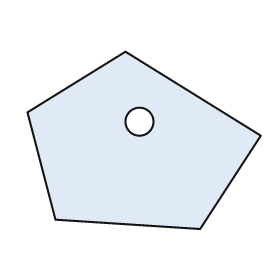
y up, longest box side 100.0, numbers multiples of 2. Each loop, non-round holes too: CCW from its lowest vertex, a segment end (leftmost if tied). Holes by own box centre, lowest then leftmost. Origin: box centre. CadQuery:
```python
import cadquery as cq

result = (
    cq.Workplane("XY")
    .moveTo(24.0, -38.0)
    .lineTo(50.0, 2.0)
    .lineTo(-8.0, 38.0)
    .lineTo(-50.0, 12.0)
    .lineTo(-38.0, -34.0)
    .close()
    .moveTo(-2.0, 8.0)
    .circle(6.0)
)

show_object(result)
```